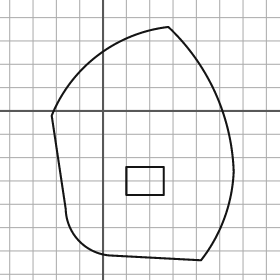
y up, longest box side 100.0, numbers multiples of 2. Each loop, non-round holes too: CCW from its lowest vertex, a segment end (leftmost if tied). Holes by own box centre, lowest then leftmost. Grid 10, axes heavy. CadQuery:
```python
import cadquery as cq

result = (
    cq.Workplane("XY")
    .moveTo(42.0, -64.0)
    .threePointArc((52.0, -46.0), (56.0, -26.0))
    .threePointArc((48.0, 8.0), (28.0, 36.0))
    .threePointArc((-2.0, 24.0), (-22.0, -2.0))
    .lineTo(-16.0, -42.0)
    .threePointArc((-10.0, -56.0), (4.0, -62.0))
    .close()
    .moveTo(10.0, -36.0)
    .lineTo(26.0, -36.0)
    .lineTo(26.0, -24.0)
    .lineTo(10.0, -24.0)
    .close()
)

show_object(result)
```